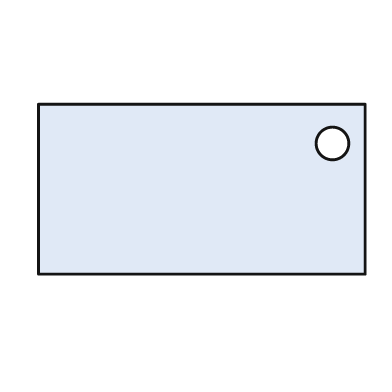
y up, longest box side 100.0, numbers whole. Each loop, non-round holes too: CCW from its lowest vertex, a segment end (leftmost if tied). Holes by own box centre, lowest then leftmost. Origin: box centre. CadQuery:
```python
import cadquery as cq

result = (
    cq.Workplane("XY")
    .moveTo(-50.0, -26.0)
    .lineTo(50.0, -26.0)
    .lineTo(50.0, 26.0)
    .lineTo(-50.0, 26.0)
    .close()
    .moveTo(40.0, 14.0)
    .circle(5.0)
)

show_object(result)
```